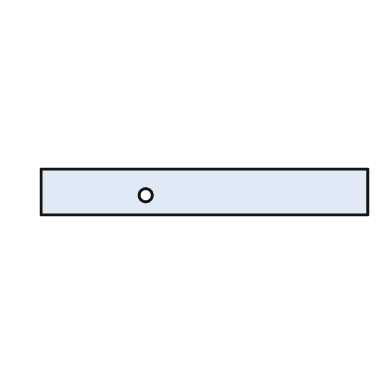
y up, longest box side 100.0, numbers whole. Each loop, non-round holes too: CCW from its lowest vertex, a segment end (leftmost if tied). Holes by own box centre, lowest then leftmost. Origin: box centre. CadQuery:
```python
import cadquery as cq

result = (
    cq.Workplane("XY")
    .moveTo(-50.0, -7.0)
    .lineTo(50.0, -7.0)
    .lineTo(50.0, 7.0)
    .lineTo(-50.0, 7.0)
    .close()
    .moveTo(-18.0, -1.0)
    .circle(2.0)
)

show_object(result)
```